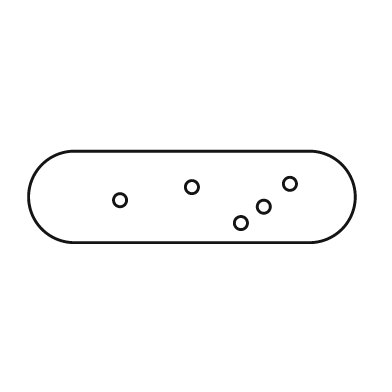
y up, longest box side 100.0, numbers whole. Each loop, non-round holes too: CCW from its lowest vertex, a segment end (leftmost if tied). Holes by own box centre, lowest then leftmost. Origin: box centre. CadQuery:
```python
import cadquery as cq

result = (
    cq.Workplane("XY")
    .moveTo(-36.0, -14.0)
    .lineTo(36.0, -14.0)
    .threePointArc((50.0, 0.0), (36.0, 14.0))
    .lineTo(-36.0, 14.0)
    .threePointArc((-50.0, 0.0), (-36.0, -14.0))
    .close()
    .moveTo(15.0, -8.0)
    .circle(2.0)
    .moveTo(22.0, -3.0)
    .circle(2.0)
    .moveTo(-22.0, -1.0)
    .circle(2.0)
    .moveTo(0.0, 3.0)
    .circle(2.0)
    .moveTo(30.0, 4.0)
    .circle(2.0)
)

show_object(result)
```